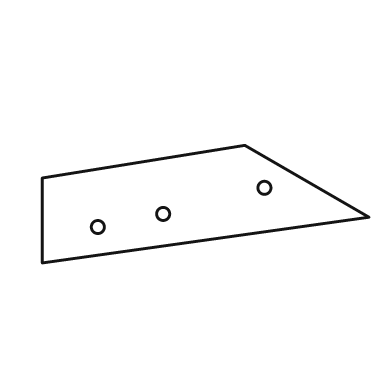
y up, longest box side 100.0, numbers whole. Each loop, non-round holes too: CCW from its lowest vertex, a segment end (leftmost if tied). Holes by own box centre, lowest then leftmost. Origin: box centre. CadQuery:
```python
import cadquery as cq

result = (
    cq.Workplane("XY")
    .moveTo(-50.0, -18.0)
    .lineTo(50.0, -4.0)
    .lineTo(12.0, 18.0)
    .lineTo(-50.0, 8.0)
    .close()
    .moveTo(-33.0, -7.0)
    .circle(2.0)
    .moveTo(-13.0, -3.0)
    .circle(2.0)
    .moveTo(18.0, 5.0)
    .circle(2.0)
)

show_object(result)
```